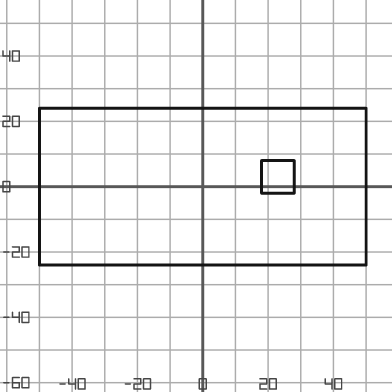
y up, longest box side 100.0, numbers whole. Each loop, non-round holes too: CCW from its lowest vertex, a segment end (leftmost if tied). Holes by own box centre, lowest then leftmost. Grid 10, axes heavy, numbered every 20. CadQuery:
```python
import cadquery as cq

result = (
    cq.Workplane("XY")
    .moveTo(-50.0, -24.0)
    .lineTo(50.0, -24.0)
    .lineTo(50.0, 24.0)
    .lineTo(-50.0, 24.0)
    .close()
    .moveTo(18.0, -2.0)
    .lineTo(28.0, -2.0)
    .lineTo(28.0, 8.0)
    .lineTo(18.0, 8.0)
    .close()
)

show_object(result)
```